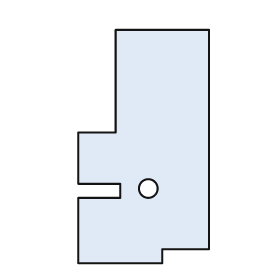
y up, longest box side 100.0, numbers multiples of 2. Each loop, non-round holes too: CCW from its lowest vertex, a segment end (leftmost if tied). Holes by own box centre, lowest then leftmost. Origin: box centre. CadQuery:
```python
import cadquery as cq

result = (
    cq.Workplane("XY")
    .moveTo(-28.0, -50.0)
    .lineTo(8.0, -50.0)
    .lineTo(8.0, -44.0)
    .lineTo(28.0, -44.0)
    .lineTo(28.0, 50.0)
    .lineTo(-12.0, 50.0)
    .lineTo(-12.0, 6.0)
    .lineTo(-28.0, 6.0)
    .lineTo(-28.0, -16.0)
    .lineTo(-10.0, -16.0)
    .lineTo(-10.0, -22.0)
    .lineTo(-28.0, -22.0)
    .close()
    .moveTo(2.0, -18.0)
    .circle(4.0)
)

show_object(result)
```